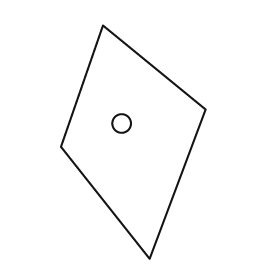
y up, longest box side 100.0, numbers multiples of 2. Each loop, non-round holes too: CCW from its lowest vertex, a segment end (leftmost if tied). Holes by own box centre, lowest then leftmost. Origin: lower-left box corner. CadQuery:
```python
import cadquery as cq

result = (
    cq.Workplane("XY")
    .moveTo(38.0, 0.0)
    .lineTo(62.0, 64.0)
    .lineTo(18.0, 100.0)
    .lineTo(0.0, 48.0)
    .close()
    .moveTo(26.0, 58.0)
    .circle(4.0)
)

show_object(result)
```